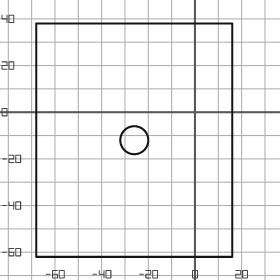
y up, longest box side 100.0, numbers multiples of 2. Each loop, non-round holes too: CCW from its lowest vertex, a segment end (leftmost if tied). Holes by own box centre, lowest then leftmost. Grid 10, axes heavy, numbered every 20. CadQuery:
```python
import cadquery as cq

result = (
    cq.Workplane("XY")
    .moveTo(-68.0, -62.0)
    .lineTo(16.0, -62.0)
    .lineTo(16.0, 38.0)
    .lineTo(-68.0, 38.0)
    .close()
    .moveTo(-26.0, -12.0)
    .circle(6.0)
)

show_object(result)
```